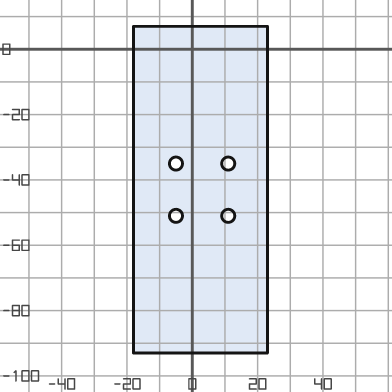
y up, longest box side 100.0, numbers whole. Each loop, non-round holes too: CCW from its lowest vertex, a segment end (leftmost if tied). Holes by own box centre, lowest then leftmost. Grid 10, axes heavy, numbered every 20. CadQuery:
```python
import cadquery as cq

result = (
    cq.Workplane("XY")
    .moveTo(-18.0, -93.0)
    .lineTo(23.0, -93.0)
    .lineTo(23.0, 7.0)
    .lineTo(-18.0, 7.0)
    .close()
    .moveTo(-5.0, -51.0)
    .circle(2.0)
    .moveTo(11.0, -51.0)
    .circle(2.0)
    .moveTo(-5.0, -35.0)
    .circle(2.0)
    .moveTo(11.0, -35.0)
    .circle(2.0)
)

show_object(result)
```